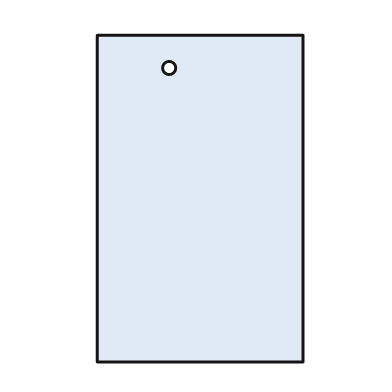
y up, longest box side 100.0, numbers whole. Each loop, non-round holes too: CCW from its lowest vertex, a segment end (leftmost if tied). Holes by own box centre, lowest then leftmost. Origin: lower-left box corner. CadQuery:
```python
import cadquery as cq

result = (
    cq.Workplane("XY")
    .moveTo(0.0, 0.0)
    .lineTo(63.0, 0.0)
    .lineTo(63.0, 100.0)
    .lineTo(0.0, 100.0)
    .close()
    .moveTo(22.0, 90.0)
    .circle(2.0)
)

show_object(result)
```